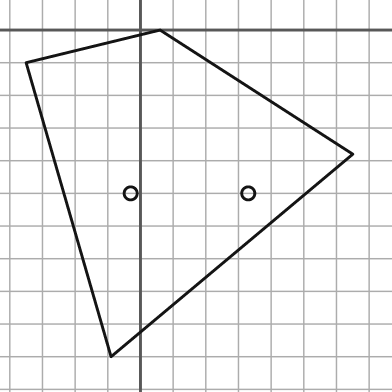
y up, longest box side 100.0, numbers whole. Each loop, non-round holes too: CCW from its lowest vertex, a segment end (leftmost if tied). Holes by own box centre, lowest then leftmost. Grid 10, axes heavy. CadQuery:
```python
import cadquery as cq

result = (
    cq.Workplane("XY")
    .moveTo(-9.0, -100.0)
    .lineTo(65.0, -38.0)
    .lineTo(6.0, 0.0)
    .lineTo(-35.0, -10.0)
    .close()
    .moveTo(-3.0, -50.0)
    .circle(2.0)
    .moveTo(33.0, -50.0)
    .circle(2.0)
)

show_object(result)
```